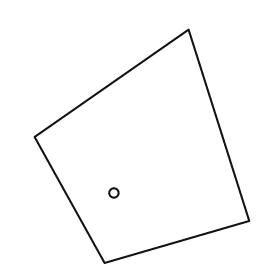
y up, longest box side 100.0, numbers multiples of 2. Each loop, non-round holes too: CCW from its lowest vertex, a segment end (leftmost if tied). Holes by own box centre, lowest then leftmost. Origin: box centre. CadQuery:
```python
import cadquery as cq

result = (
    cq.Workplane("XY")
    .moveTo(-16.0, -50.0)
    .lineTo(46.0, -32.0)
    .lineTo(20.0, 50.0)
    .lineTo(-46.0, 4.0)
    .close()
    .moveTo(-12.0, -20.0)
    .circle(2.0)
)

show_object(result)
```